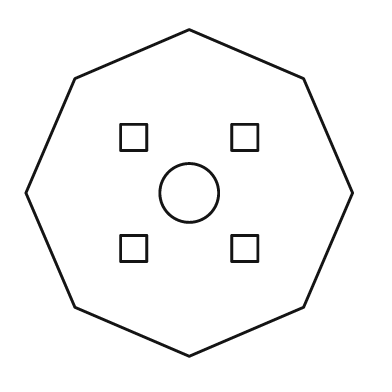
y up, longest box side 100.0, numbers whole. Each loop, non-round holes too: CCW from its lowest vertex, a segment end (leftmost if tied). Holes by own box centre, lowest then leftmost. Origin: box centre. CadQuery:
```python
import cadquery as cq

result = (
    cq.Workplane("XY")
    .moveTo(0.0, -50.0)
    .lineTo(35.0, -35.0)
    .lineTo(50.0, 0.0)
    .lineTo(35.0, 35.0)
    .lineTo(0.0, 50.0)
    .lineTo(-35.0, 35.0)
    .lineTo(-50.0, 0.0)
    .lineTo(-35.0, -35.0)
    .close()
    .moveTo(-21.0, -21.0)
    .lineTo(-13.0, -21.0)
    .lineTo(-13.0, -13.0)
    .lineTo(-21.0, -13.0)
    .close()
    .moveTo(13.0, -21.0)
    .lineTo(21.0, -21.0)
    .lineTo(21.0, -13.0)
    .lineTo(13.0, -13.0)
    .close()
    .moveTo(0.0, 0.0)
    .circle(9.0)
    .moveTo(-21.0, 13.0)
    .lineTo(-13.0, 13.0)
    .lineTo(-13.0, 21.0)
    .lineTo(-21.0, 21.0)
    .close()
    .moveTo(13.0, 13.0)
    .lineTo(21.0, 13.0)
    .lineTo(21.0, 21.0)
    .lineTo(13.0, 21.0)
    .close()
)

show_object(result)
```